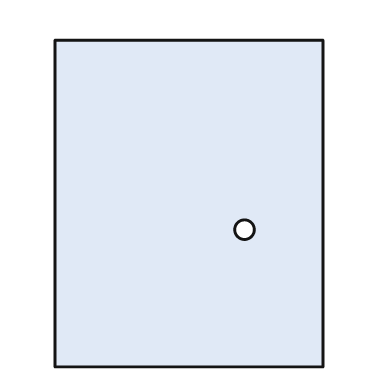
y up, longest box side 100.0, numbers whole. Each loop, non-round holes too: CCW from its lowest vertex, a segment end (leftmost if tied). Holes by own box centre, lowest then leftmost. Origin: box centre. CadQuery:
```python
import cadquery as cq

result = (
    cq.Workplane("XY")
    .moveTo(-41.0, -50.0)
    .lineTo(41.0, -50.0)
    .lineTo(41.0, 50.0)
    .lineTo(-41.0, 50.0)
    .close()
    .moveTo(17.0, -8.0)
    .circle(3.0)
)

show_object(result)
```